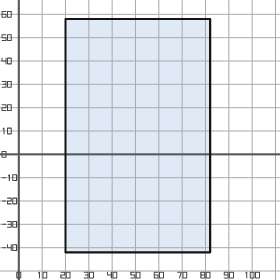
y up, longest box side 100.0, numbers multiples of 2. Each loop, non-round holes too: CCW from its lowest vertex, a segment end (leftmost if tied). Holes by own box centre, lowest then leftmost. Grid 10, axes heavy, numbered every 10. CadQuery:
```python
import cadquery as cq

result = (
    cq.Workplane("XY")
    .moveTo(20.0, -42.0)
    .lineTo(82.0, -42.0)
    .lineTo(82.0, 58.0)
    .lineTo(20.0, 58.0)
    .close()
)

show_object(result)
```